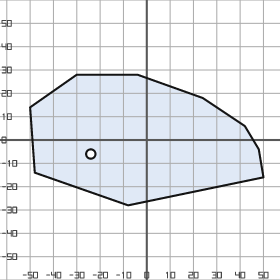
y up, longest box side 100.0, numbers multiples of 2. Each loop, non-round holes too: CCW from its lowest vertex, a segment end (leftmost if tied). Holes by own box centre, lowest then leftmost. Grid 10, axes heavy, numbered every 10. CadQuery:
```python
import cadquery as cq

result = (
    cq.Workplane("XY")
    .moveTo(-8.0, -28.0)
    .lineTo(50.0, -16.0)
    .lineTo(48.0, -4.0)
    .lineTo(42.0, 6.0)
    .lineTo(24.0, 18.0)
    .lineTo(-4.0, 28.0)
    .lineTo(-30.0, 28.0)
    .lineTo(-50.0, 14.0)
    .lineTo(-48.0, -14.0)
    .close()
    .moveTo(-24.0, -6.0)
    .circle(2.0)
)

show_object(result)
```